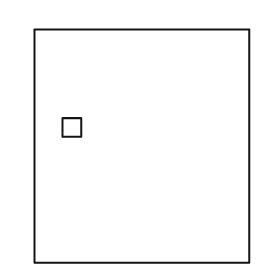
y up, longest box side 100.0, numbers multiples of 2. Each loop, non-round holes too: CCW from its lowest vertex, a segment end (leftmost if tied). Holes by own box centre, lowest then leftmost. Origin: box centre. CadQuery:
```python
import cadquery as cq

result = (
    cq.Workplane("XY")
    .moveTo(-46.0, -50.0)
    .lineTo(46.0, -50.0)
    .lineTo(46.0, 50.0)
    .lineTo(-46.0, 50.0)
    .close()
    .moveTo(-34.0, 4.0)
    .lineTo(-26.0, 4.0)
    .lineTo(-26.0, 12.0)
    .lineTo(-34.0, 12.0)
    .close()
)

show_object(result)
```